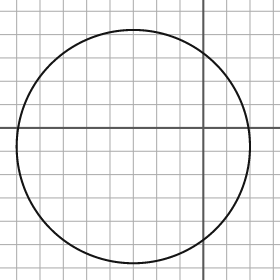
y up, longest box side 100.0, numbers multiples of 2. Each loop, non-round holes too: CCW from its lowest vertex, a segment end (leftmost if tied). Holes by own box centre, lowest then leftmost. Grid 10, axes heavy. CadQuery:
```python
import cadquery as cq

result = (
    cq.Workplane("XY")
    .moveTo(-30.0, -8.0)
    .circle(50.0)
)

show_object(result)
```